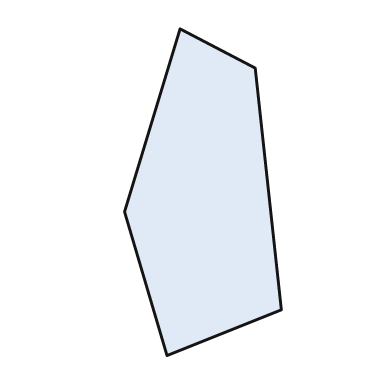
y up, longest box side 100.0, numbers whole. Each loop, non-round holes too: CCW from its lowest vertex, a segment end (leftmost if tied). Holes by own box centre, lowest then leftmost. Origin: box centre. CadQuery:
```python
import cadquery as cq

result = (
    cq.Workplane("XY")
    .moveTo(-11.0, -50.0)
    .lineTo(24.0, -36.0)
    .lineTo(16.0, 38.0)
    .lineTo(-7.0, 50.0)
    .lineTo(-24.0, -6.0)
    .close()
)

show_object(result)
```